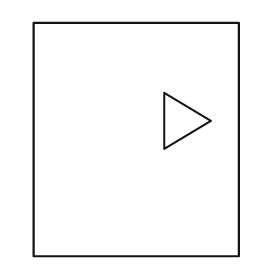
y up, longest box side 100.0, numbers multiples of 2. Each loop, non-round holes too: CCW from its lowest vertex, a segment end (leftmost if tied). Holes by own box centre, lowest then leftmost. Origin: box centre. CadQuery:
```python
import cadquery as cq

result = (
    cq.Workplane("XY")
    .moveTo(-44.0, -50.0)
    .lineTo(44.0, -50.0)
    .lineTo(44.0, 50.0)
    .lineTo(-44.0, 50.0)
    .close()
    .moveTo(12.0, -4.0)
    .lineTo(32.0, 8.0)
    .lineTo(12.0, 20.0)
    .close()
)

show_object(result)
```